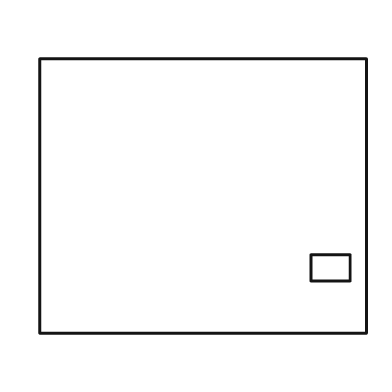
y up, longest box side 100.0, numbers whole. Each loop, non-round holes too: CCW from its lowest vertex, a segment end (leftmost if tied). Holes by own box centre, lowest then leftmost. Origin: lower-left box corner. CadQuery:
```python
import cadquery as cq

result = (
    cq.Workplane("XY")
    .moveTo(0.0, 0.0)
    .lineTo(100.0, 0.0)
    .lineTo(100.0, 84.0)
    .lineTo(0.0, 84.0)
    .close()
    .moveTo(83.0, 16.0)
    .lineTo(95.0, 16.0)
    .lineTo(95.0, 24.0)
    .lineTo(83.0, 24.0)
    .close()
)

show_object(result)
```